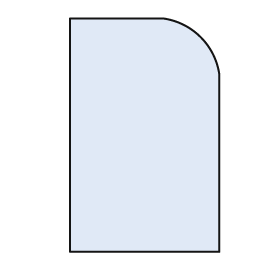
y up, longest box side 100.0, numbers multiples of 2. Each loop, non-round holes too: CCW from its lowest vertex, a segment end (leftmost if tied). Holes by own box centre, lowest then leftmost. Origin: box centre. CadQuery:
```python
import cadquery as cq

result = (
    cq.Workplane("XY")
    .moveTo(-32.0, -50.0)
    .lineTo(32.0, -50.0)
    .lineTo(32.0, 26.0)
    .threePointArc((24.0, 42.0), (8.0, 50.0))
    .lineTo(-32.0, 50.0)
    .close()
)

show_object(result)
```